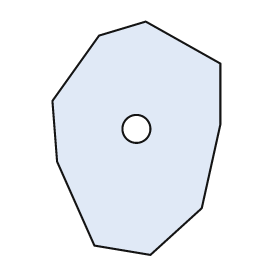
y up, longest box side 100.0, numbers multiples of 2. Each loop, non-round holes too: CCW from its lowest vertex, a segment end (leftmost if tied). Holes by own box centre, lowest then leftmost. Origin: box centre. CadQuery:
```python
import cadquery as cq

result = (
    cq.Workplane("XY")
    .moveTo(6.0, -50.0)
    .lineTo(28.0, -30.0)
    .lineTo(36.0, 6.0)
    .lineTo(36.0, 32.0)
    .lineTo(4.0, 50.0)
    .lineTo(-16.0, 44.0)
    .lineTo(-36.0, 16.0)
    .lineTo(-34.0, -10.0)
    .lineTo(-18.0, -46.0)
    .close()
    .moveTo(0.0, 4.0)
    .circle(6.0)
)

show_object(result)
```